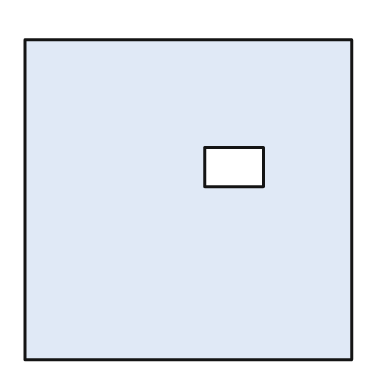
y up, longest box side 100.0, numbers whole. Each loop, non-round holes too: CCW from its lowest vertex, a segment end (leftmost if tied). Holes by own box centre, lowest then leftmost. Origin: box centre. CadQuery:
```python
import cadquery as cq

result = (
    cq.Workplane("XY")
    .moveTo(-50.0, -49.0)
    .lineTo(50.0, -49.0)
    .lineTo(50.0, 49.0)
    .lineTo(-50.0, 49.0)
    .close()
    .moveTo(5.0, 4.0)
    .lineTo(23.0, 4.0)
    .lineTo(23.0, 16.0)
    .lineTo(5.0, 16.0)
    .close()
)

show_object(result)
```